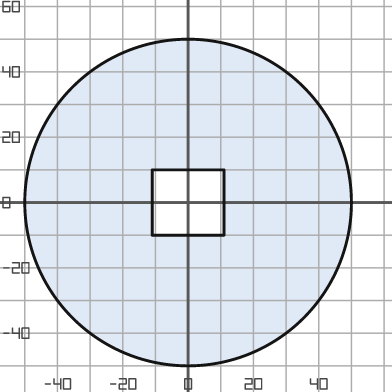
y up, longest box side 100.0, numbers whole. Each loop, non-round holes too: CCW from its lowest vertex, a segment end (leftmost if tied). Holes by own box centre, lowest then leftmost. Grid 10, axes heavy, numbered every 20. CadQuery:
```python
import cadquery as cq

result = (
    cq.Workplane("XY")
    .moveTo(0.0, 0.0)
    .circle(50.0)
    .moveTo(-11.0, -10.0)
    .lineTo(11.0, -10.0)
    .lineTo(11.0, 10.0)
    .lineTo(-11.0, 10.0)
    .close()
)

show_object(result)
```